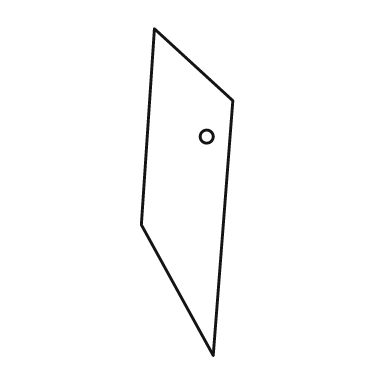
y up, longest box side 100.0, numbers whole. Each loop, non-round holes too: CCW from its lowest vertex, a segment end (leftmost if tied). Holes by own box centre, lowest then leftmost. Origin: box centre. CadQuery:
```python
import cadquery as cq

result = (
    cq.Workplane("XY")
    .moveTo(8.0, -50.0)
    .lineTo(14.0, 28.0)
    .lineTo(-10.0, 50.0)
    .lineTo(-14.0, -10.0)
    .close()
    .moveTo(6.0, 17.0)
    .circle(2.0)
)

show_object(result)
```